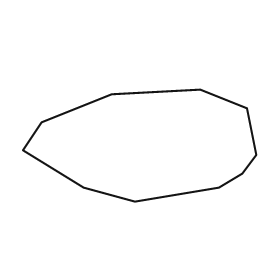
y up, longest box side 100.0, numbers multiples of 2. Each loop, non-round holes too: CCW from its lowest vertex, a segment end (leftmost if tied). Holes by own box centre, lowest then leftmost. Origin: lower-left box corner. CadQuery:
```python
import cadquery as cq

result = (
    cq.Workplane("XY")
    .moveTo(48.0, 0.0)
    .lineTo(84.0, 6.0)
    .lineTo(94.0, 12.0)
    .lineTo(100.0, 20.0)
    .lineTo(96.0, 40.0)
    .lineTo(76.0, 48.0)
    .lineTo(38.0, 46.0)
    .lineTo(8.0, 34.0)
    .lineTo(0.0, 22.0)
    .lineTo(26.0, 6.0)
    .close()
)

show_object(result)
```